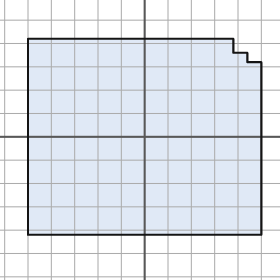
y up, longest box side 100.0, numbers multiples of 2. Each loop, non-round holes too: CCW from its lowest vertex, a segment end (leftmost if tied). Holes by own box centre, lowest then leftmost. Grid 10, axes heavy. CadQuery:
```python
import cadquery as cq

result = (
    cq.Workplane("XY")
    .moveTo(-50.0, -42.0)
    .lineTo(50.0, -42.0)
    .lineTo(50.0, 32.0)
    .lineTo(44.0, 32.0)
    .lineTo(44.0, 36.0)
    .lineTo(38.0, 36.0)
    .lineTo(38.0, 42.0)
    .lineTo(-50.0, 42.0)
    .close()
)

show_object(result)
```